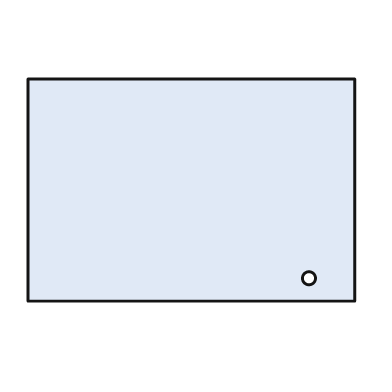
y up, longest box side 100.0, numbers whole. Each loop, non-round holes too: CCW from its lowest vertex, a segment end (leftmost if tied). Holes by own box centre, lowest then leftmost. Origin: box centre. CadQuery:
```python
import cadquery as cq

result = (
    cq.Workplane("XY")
    .moveTo(-50.0, -34.0)
    .lineTo(50.0, -34.0)
    .lineTo(50.0, 34.0)
    .lineTo(-50.0, 34.0)
    .close()
    .moveTo(36.0, -27.0)
    .circle(2.0)
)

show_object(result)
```